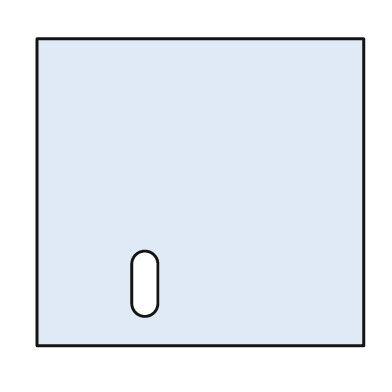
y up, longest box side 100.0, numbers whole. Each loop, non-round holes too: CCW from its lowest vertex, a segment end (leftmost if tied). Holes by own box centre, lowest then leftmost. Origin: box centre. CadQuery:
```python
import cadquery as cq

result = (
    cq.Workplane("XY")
    .moveTo(-50.0, -47.0)
    .lineTo(50.0, -47.0)
    .lineTo(50.0, 47.0)
    .lineTo(-50.0, 47.0)
    .close()
    .moveTo(-21.0, -34.0)
    .threePointArc((-17.0, -38.0), (-13.0, -34.0))
    .lineTo(-13.0, -22.0)
    .threePointArc((-17.0, -18.0), (-21.0, -22.0))
    .close()
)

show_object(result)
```